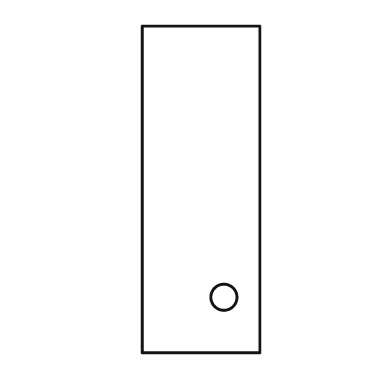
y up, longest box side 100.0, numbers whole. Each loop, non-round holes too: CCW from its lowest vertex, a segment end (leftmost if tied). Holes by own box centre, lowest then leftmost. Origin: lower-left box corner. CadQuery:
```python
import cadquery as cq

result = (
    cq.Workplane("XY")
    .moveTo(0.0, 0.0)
    .lineTo(36.0, 0.0)
    .lineTo(36.0, 100.0)
    .lineTo(0.0, 100.0)
    .close()
    .moveTo(25.0, 17.0)
    .circle(4.0)
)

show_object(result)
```